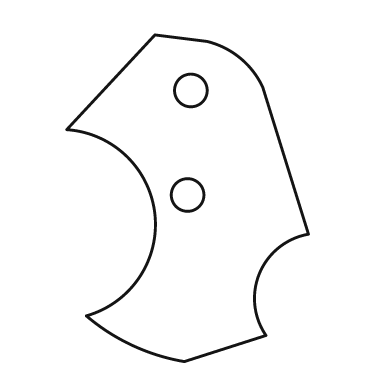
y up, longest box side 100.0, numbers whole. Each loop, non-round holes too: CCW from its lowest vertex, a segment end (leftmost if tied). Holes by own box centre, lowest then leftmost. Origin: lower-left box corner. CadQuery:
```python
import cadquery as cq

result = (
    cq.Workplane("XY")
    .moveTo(36.0, 0.0)
    .lineTo(61.0, 8.0)
    .threePointArc((59.0, 27.0), (74.0, 39.0))
    .lineTo(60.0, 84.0)
    .threePointArc((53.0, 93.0), (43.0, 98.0))
    .lineTo(27.0, 100.0)
    .lineTo(0.0, 71.0)
    .threePointArc((27.0, 45.0), (6.0, 14.0))
    .threePointArc((20.0, 5.0), (36.0, 0.0))
    .close()
    .moveTo(37.0, 51.0)
    .circle(5.0)
    .moveTo(38.0, 83.0)
    .circle(5.0)
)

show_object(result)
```